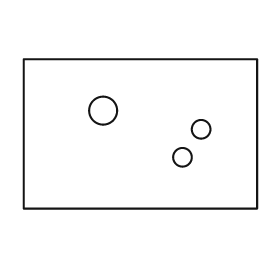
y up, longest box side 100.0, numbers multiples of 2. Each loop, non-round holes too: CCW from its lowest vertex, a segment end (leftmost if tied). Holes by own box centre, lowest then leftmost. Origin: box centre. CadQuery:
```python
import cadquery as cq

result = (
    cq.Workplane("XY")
    .moveTo(-50.0, -32.0)
    .lineTo(50.0, -32.0)
    .lineTo(50.0, 32.0)
    .lineTo(-50.0, 32.0)
    .close()
    .moveTo(18.0, -10.0)
    .circle(4.0)
    .moveTo(26.0, 2.0)
    .circle(4.0)
    .moveTo(-16.0, 10.0)
    .circle(6.0)
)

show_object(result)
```